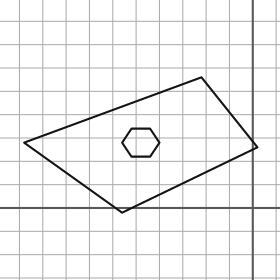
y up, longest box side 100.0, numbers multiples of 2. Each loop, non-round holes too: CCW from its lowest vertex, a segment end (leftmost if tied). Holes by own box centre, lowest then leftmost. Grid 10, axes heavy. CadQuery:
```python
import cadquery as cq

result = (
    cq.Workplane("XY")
    .moveTo(-56.0, -2.0)
    .lineTo(2.0, 26.0)
    .lineTo(-22.0, 56.0)
    .lineTo(-98.0, 28.0)
    .close()
    .moveTo(-52.0, 22.0)
    .lineTo(-44.0, 22.0)
    .lineTo(-40.0, 28.0)
    .lineTo(-44.0, 34.0)
    .lineTo(-52.0, 34.0)
    .lineTo(-56.0, 28.0)
    .close()
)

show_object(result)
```